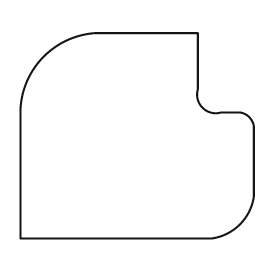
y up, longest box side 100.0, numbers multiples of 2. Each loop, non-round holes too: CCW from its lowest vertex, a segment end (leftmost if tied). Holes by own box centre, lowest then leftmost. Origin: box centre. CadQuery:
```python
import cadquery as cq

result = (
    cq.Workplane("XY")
    .moveTo(-50.0, -44.0)
    .lineTo(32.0, -44.0)
    .threePointArc((44.0, -38.0), (50.0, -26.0))
    .lineTo(50.0, 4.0)
    .threePointArc((48.0, 8.0), (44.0, 10.0))
    .lineTo(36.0, 10.0)
    .threePointArc((28.0, 12.0), (26.0, 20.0))
    .lineTo(26.0, 44.0)
    .lineTo(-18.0, 44.0)
    .threePointArc((-40.0, 34.0), (-50.0, 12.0))
    .close()
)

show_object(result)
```